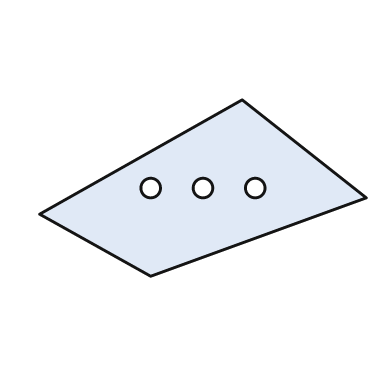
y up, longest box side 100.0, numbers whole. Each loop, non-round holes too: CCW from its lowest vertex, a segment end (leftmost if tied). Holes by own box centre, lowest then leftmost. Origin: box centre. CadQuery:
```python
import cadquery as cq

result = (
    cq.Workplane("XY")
    .moveTo(-16.0, -27.0)
    .lineTo(50.0, -3.0)
    .lineTo(12.0, 27.0)
    .lineTo(-50.0, -8.0)
    .close()
    .moveTo(-16.0, 0.0)
    .circle(3.0)
    .moveTo(0.0, 0.0)
    .circle(3.0)
    .moveTo(16.0, 0.0)
    .circle(3.0)
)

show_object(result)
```